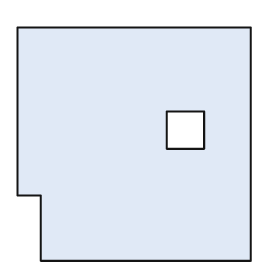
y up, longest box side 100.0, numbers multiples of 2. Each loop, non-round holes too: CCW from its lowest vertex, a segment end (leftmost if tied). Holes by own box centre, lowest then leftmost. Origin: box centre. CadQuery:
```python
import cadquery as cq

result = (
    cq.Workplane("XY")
    .moveTo(-40.0, -50.0)
    .lineTo(50.0, -50.0)
    .lineTo(50.0, 50.0)
    .lineTo(-50.0, 50.0)
    .lineTo(-50.0, -22.0)
    .lineTo(-40.0, -22.0)
    .close()
    .moveTo(14.0, -2.0)
    .lineTo(30.0, -2.0)
    .lineTo(30.0, 14.0)
    .lineTo(14.0, 14.0)
    .close()
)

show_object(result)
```